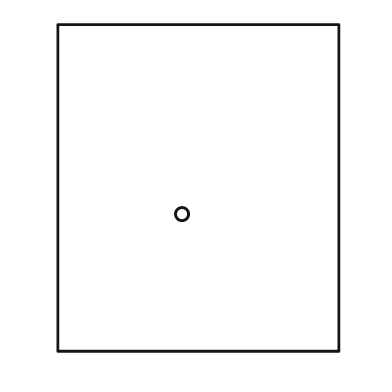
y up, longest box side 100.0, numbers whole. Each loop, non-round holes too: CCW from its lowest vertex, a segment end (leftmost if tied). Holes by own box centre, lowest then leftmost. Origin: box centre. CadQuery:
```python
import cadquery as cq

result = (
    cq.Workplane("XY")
    .moveTo(-43.0, -50.0)
    .lineTo(43.0, -50.0)
    .lineTo(43.0, 50.0)
    .lineTo(-43.0, 50.0)
    .close()
    .moveTo(-5.0, -8.0)
    .circle(2.0)
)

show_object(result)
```